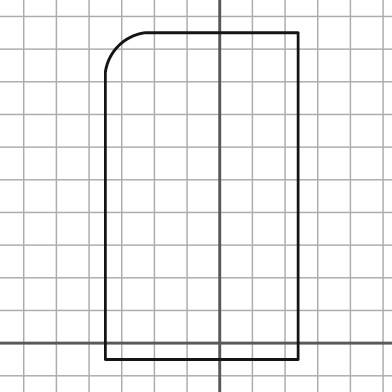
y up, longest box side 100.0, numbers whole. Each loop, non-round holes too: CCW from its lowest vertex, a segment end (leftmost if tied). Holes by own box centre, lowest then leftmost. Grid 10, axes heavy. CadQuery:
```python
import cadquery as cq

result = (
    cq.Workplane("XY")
    .moveTo(-35.0, -5.0)
    .lineTo(24.0, -5.0)
    .lineTo(24.0, 95.0)
    .lineTo(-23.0, 95.0)
    .threePointArc((-31.0, 91.0), (-35.0, 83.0))
    .close()
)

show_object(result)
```